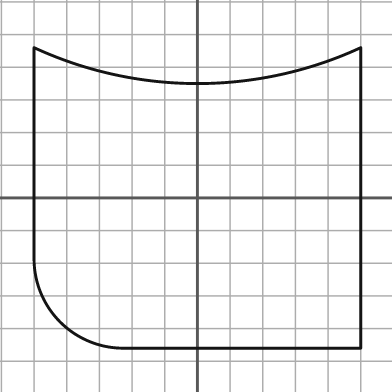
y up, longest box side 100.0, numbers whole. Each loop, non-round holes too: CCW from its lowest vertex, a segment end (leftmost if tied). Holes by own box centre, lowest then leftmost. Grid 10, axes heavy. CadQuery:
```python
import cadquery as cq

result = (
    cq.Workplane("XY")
    .moveTo(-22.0, -46.0)
    .lineTo(50.0, -46.0)
    .lineTo(50.0, 46.0)
    .threePointArc((0.0, 35.0), (-50.0, 46.0))
    .lineTo(-50.0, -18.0)
    .threePointArc((-42.0, -38.0), (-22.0, -46.0))
    .close()
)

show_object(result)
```